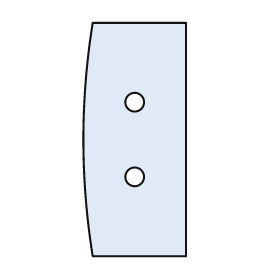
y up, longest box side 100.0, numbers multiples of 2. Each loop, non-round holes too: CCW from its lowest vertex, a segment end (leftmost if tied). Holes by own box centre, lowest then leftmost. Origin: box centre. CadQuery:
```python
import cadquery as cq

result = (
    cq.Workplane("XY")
    .moveTo(-18.0, -50.0)
    .lineTo(22.0, -50.0)
    .lineTo(22.0, 50.0)
    .lineTo(-18.0, 50.0)
    .threePointArc((-22.0, 0.0), (-18.0, -50.0))
    .close()
    .moveTo(0.0, -16.0)
    .circle(4.0)
    .moveTo(0.0, 16.0)
    .circle(4.0)
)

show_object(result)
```